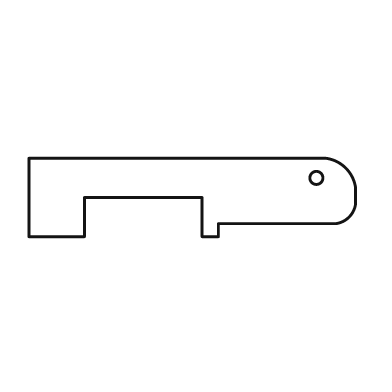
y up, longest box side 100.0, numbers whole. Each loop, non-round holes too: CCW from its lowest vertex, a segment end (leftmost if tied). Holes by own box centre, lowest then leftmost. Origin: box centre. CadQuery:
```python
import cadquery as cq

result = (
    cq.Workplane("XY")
    .moveTo(-50.0, -12.0)
    .lineTo(-33.0, -12.0)
    .lineTo(-33.0, 0.0)
    .lineTo(3.0, 0.0)
    .lineTo(3.0, -12.0)
    .lineTo(8.0, -12.0)
    .lineTo(8.0, -8.0)
    .lineTo(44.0, -8.0)
    .threePointArc((48.0, -6.0), (50.0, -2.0))
    .lineTo(50.0, 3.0)
    .threePointArc((47.0, 9.0), (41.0, 12.0))
    .lineTo(-50.0, 12.0)
    .close()
    .moveTo(38.0, 6.0)
    .circle(2.0)
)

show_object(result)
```